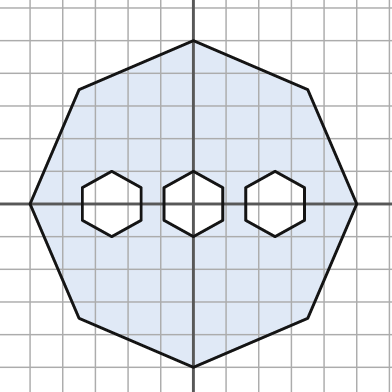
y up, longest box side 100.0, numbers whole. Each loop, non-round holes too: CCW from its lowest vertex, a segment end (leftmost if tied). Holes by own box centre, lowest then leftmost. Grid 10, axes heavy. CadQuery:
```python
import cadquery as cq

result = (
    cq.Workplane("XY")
    .moveTo(0.0, -50.0)
    .lineTo(35.0, -35.0)
    .lineTo(50.0, 0.0)
    .lineTo(35.0, 35.0)
    .lineTo(0.0, 50.0)
    .lineTo(-35.0, 35.0)
    .lineTo(-50.0, 0.0)
    .lineTo(-35.0, -35.0)
    .close()
    .moveTo(-25.0, -10.0)
    .lineTo(-16.0, -5.0)
    .lineTo(-16.0, 5.0)
    .lineTo(-25.0, 10.0)
    .lineTo(-34.0, 5.0)
    .lineTo(-34.0, -5.0)
    .close()
    .moveTo(0.0, -10.0)
    .lineTo(9.0, -5.0)
    .lineTo(9.0, 5.0)
    .lineTo(0.0, 10.0)
    .lineTo(-9.0, 5.0)
    .lineTo(-9.0, -5.0)
    .close()
    .moveTo(25.0, -10.0)
    .lineTo(34.0, -5.0)
    .lineTo(34.0, 5.0)
    .lineTo(25.0, 10.0)
    .lineTo(16.0, 5.0)
    .lineTo(16.0, -5.0)
    .close()
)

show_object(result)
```